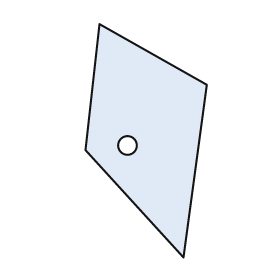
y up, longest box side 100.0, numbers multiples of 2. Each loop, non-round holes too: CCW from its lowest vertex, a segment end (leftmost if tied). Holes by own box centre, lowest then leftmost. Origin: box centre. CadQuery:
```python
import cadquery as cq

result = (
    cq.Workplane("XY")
    .moveTo(16.0, -50.0)
    .lineTo(26.0, 24.0)
    .lineTo(-20.0, 50.0)
    .lineTo(-26.0, -4.0)
    .close()
    .moveTo(-8.0, -2.0)
    .circle(4.0)
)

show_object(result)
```